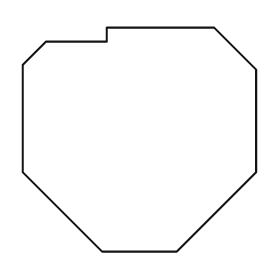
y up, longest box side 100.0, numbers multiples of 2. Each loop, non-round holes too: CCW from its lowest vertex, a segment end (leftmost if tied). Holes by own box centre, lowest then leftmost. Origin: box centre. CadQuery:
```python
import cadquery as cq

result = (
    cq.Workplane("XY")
    .moveTo(-16.0, -48.0)
    .lineTo(16.0, -48.0)
    .lineTo(50.0, -14.0)
    .lineTo(50.0, 30.0)
    .lineTo(32.0, 48.0)
    .lineTo(-14.0, 48.0)
    .lineTo(-14.0, 42.0)
    .lineTo(-40.0, 42.0)
    .lineTo(-50.0, 32.0)
    .lineTo(-50.0, -14.0)
    .close()
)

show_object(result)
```